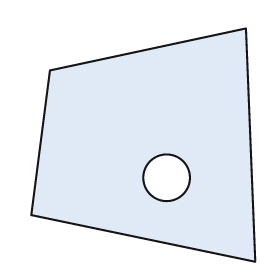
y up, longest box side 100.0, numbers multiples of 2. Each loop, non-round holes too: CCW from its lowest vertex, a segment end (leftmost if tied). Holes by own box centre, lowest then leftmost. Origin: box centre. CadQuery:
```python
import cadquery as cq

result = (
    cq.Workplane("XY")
    .moveTo(48.0, -50.0)
    .lineTo(44.0, 50.0)
    .lineTo(-40.0, 32.0)
    .lineTo(-48.0, -30.0)
    .close()
    .moveTo(10.0, -14.0)
    .circle(10.0)
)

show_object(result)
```